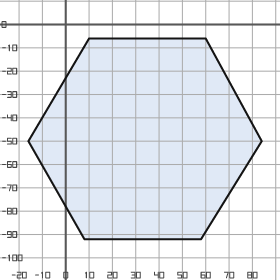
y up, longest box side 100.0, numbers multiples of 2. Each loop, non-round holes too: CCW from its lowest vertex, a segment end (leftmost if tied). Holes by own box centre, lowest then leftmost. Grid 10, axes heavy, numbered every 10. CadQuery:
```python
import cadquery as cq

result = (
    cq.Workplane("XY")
    .moveTo(8.0, -92.0)
    .lineTo(58.0, -92.0)
    .lineTo(84.0, -50.0)
    .lineTo(60.0, -6.0)
    .lineTo(10.0, -6.0)
    .lineTo(-16.0, -50.0)
    .close()
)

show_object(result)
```